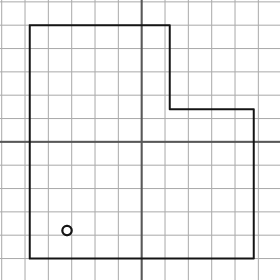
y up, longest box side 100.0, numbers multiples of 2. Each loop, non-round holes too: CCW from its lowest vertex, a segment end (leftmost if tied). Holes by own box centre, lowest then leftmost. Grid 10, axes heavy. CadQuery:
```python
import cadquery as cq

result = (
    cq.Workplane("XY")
    .moveTo(-48.0, -50.0)
    .lineTo(48.0, -50.0)
    .lineTo(48.0, 14.0)
    .lineTo(12.0, 14.0)
    .lineTo(12.0, 50.0)
    .lineTo(-48.0, 50.0)
    .close()
    .moveTo(-32.0, -38.0)
    .circle(2.0)
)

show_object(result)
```